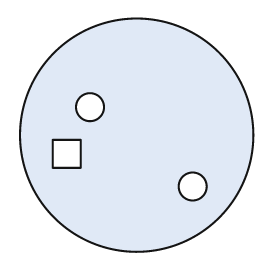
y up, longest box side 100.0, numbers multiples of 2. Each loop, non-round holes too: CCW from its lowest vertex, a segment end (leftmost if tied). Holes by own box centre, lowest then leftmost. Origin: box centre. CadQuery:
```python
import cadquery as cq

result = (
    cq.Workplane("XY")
    .moveTo(0.0, 0.0)
    .circle(50.0)
    .moveTo(24.0, -22.0)
    .circle(6.0)
    .moveTo(-36.0, -14.0)
    .lineTo(-24.0, -14.0)
    .lineTo(-24.0, -2.0)
    .lineTo(-36.0, -2.0)
    .close()
    .moveTo(-20.0, 12.0)
    .circle(6.0)
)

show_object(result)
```